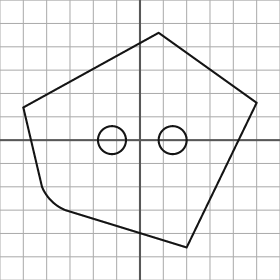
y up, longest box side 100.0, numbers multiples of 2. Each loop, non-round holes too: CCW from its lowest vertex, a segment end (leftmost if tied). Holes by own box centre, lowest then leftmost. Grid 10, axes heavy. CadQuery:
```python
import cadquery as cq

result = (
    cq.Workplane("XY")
    .moveTo(20.0, -46.0)
    .lineTo(50.0, 16.0)
    .lineTo(8.0, 46.0)
    .lineTo(-50.0, 14.0)
    .lineTo(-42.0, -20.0)
    .threePointArc((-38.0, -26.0), (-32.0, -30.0))
    .close()
    .moveTo(-12.0, 0.0)
    .circle(6.0)
    .moveTo(14.0, 0.0)
    .circle(6.0)
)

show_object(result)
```